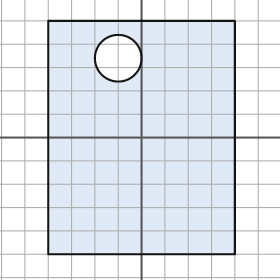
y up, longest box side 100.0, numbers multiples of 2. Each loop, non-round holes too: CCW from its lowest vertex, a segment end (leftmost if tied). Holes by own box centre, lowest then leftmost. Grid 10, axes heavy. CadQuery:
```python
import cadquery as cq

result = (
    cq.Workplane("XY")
    .moveTo(-40.0, -50.0)
    .lineTo(40.0, -50.0)
    .lineTo(40.0, 50.0)
    .lineTo(-40.0, 50.0)
    .close()
    .moveTo(-10.0, 34.0)
    .circle(10.0)
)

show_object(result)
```